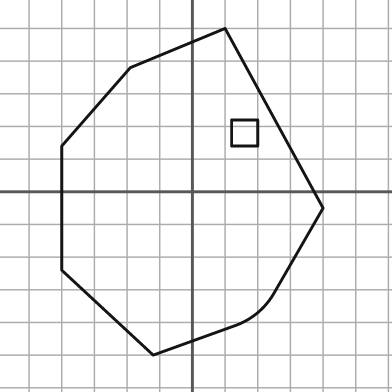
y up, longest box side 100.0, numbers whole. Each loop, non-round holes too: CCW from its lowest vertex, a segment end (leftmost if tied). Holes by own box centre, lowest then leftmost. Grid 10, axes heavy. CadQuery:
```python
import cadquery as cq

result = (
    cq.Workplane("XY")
    .moveTo(-12.0, -50.0)
    .lineTo(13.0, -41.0)
    .threePointArc((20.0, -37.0), (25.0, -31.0))
    .lineTo(40.0, -5.0)
    .lineTo(10.0, 50.0)
    .lineTo(-19.0, 38.0)
    .lineTo(-40.0, 14.0)
    .lineTo(-40.0, -24.0)
    .close()
    .moveTo(12.0, 14.0)
    .lineTo(20.0, 14.0)
    .lineTo(20.0, 22.0)
    .lineTo(12.0, 22.0)
    .close()
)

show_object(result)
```